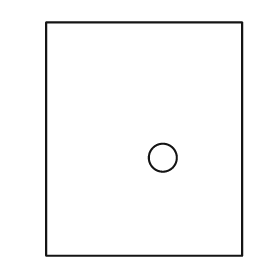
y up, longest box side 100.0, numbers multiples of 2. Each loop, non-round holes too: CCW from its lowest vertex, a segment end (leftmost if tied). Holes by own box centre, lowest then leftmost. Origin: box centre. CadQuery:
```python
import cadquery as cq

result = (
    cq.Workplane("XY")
    .moveTo(-42.0, -50.0)
    .lineTo(42.0, -50.0)
    .lineTo(42.0, 50.0)
    .lineTo(-42.0, 50.0)
    .close()
    .moveTo(8.0, -8.0)
    .circle(6.0)
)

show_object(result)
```